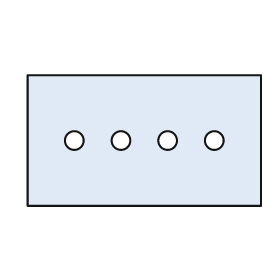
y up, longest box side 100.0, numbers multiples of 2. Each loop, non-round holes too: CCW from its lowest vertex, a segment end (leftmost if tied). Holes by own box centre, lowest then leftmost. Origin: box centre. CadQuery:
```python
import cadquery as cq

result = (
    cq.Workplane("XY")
    .moveTo(-50.0, -28.0)
    .lineTo(50.0, -28.0)
    .lineTo(50.0, 28.0)
    .lineTo(-50.0, 28.0)
    .close()
    .moveTo(-30.0, 0.0)
    .circle(4.0)
    .moveTo(-10.0, 0.0)
    .circle(4.0)
    .moveTo(10.0, 0.0)
    .circle(4.0)
    .moveTo(30.0, 0.0)
    .circle(4.0)
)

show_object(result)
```